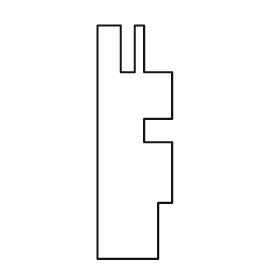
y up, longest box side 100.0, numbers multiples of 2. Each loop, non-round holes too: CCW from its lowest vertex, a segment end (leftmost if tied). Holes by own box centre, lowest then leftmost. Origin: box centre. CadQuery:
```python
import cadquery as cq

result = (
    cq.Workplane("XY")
    .moveTo(-16.0, -50.0)
    .lineTo(10.0, -50.0)
    .lineTo(10.0, -26.0)
    .lineTo(16.0, -26.0)
    .lineTo(16.0, 0.0)
    .lineTo(4.0, 0.0)
    .lineTo(4.0, 10.0)
    .lineTo(16.0, 10.0)
    .lineTo(16.0, 30.0)
    .lineTo(4.0, 30.0)
    .lineTo(4.0, 50.0)
    .lineTo(0.0, 50.0)
    .lineTo(0.0, 30.0)
    .lineTo(-6.0, 30.0)
    .lineTo(-6.0, 50.0)
    .lineTo(-16.0, 50.0)
    .close()
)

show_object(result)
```